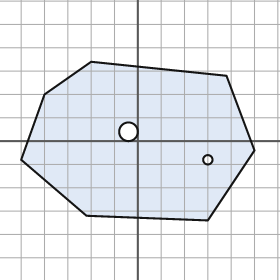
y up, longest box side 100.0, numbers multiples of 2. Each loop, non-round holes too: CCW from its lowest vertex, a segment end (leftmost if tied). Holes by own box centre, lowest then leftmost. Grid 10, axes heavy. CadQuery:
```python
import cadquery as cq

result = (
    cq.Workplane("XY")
    .moveTo(30.0, -34.0)
    .lineTo(50.0, -4.0)
    .lineTo(38.0, 28.0)
    .lineTo(-20.0, 34.0)
    .lineTo(-40.0, 20.0)
    .lineTo(-50.0, -8.0)
    .lineTo(-22.0, -32.0)
    .close()
    .moveTo(30.0, -8.0)
    .circle(2.0)
    .moveTo(-4.0, 4.0)
    .circle(4.0)
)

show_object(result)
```